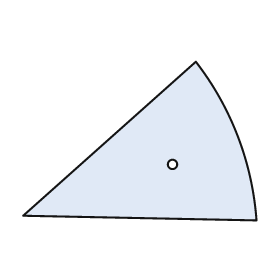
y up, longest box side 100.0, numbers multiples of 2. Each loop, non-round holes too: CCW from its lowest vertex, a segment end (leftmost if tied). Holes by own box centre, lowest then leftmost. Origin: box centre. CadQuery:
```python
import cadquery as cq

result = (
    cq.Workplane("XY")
    .moveTo(50.0, -34.0)
    .threePointArc((42.0, 2.0), (24.0, 34.0))
    .lineTo(-50.0, -32.0)
    .close()
    .moveTo(14.0, -10.0)
    .circle(2.0)
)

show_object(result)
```